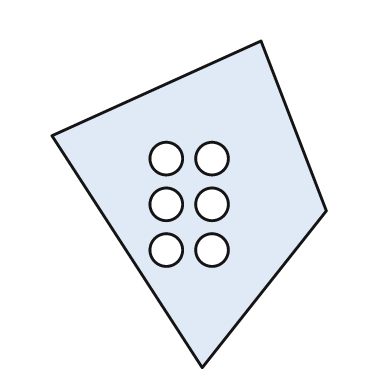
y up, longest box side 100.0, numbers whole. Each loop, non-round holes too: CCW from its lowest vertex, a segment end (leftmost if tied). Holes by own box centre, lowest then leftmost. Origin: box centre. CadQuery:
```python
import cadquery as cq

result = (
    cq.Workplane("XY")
    .moveTo(4.0, -50.0)
    .lineTo(42.0, -2.0)
    .lineTo(22.0, 50.0)
    .lineTo(-42.0, 21.0)
    .close()
    .moveTo(-7.0, -14.0)
    .circle(5.0)
    .moveTo(7.0, -14.0)
    .circle(5.0)
    .moveTo(-7.0, 0.0)
    .circle(5.0)
    .moveTo(7.0, 0.0)
    .circle(5.0)
    .moveTo(-7.0, 14.0)
    .circle(5.0)
    .moveTo(7.0, 14.0)
    .circle(5.0)
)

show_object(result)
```